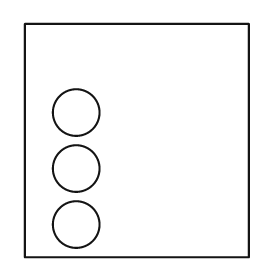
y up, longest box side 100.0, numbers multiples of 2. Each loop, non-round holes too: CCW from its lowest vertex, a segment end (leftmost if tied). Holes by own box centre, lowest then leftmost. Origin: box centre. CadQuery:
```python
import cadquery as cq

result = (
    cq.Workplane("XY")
    .moveTo(-48.0, -50.0)
    .lineTo(48.0, -50.0)
    .lineTo(48.0, 50.0)
    .lineTo(-48.0, 50.0)
    .close()
    .moveTo(-26.0, -36.0)
    .circle(10.0)
    .moveTo(-26.0, -12.0)
    .circle(10.0)
    .moveTo(-26.0, 12.0)
    .circle(10.0)
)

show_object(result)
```